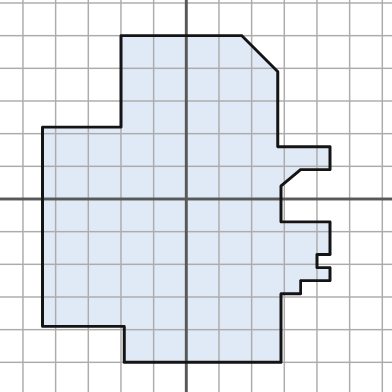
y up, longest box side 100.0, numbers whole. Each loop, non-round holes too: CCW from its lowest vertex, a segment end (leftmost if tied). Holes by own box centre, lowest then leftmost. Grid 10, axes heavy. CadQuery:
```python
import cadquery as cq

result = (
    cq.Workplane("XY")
    .moveTo(-19.0, -50.0)
    .lineTo(29.0, -50.0)
    .lineTo(29.0, -29.0)
    .lineTo(35.0, -29.0)
    .lineTo(35.0, -25.0)
    .lineTo(44.0, -25.0)
    .lineTo(44.0, -21.0)
    .lineTo(40.0, -21.0)
    .lineTo(40.0, -17.0)
    .lineTo(44.0, -17.0)
    .lineTo(44.0, -7.0)
    .lineTo(29.0, -7.0)
    .lineTo(29.0, 4.0)
    .lineTo(35.0, 9.0)
    .lineTo(44.0, 9.0)
    .lineTo(44.0, 16.0)
    .lineTo(28.0, 16.0)
    .lineTo(28.0, 39.0)
    .lineTo(17.0, 50.0)
    .lineTo(-20.0, 50.0)
    .lineTo(-20.0, 22.0)
    .lineTo(-44.0, 22.0)
    .lineTo(-44.0, -39.0)
    .lineTo(-19.0, -39.0)
    .close()
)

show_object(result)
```